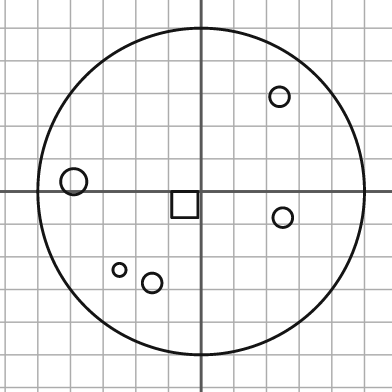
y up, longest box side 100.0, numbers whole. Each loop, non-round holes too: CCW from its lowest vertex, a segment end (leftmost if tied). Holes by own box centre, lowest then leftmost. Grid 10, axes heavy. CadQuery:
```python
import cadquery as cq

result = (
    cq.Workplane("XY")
    .moveTo(0.0, 0.0)
    .circle(50.0)
    .moveTo(-15.0, -28.0)
    .circle(3.0)
    .moveTo(-25.0, -24.0)
    .circle(2.0)
    .moveTo(25.0, -8.0)
    .circle(3.0)
    .moveTo(-9.0, -8.0)
    .lineTo(-1.0, -8.0)
    .lineTo(-1.0, 0.0)
    .lineTo(-9.0, 0.0)
    .close()
    .moveTo(-39.0, 3.0)
    .circle(4.0)
    .moveTo(24.0, 29.0)
    .circle(3.0)
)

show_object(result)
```